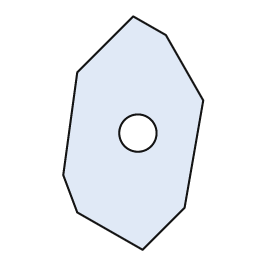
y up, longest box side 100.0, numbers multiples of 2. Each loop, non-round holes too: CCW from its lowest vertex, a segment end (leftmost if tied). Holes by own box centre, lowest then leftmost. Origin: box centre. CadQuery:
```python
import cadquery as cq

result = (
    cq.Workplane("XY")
    .moveTo(4.0, -50.0)
    .lineTo(22.0, -32.0)
    .lineTo(30.0, 14.0)
    .lineTo(14.0, 42.0)
    .lineTo(0.0, 50.0)
    .lineTo(-24.0, 26.0)
    .lineTo(-30.0, -18.0)
    .lineTo(-24.0, -34.0)
    .close()
    .moveTo(2.0, 0.0)
    .circle(8.0)
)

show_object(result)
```